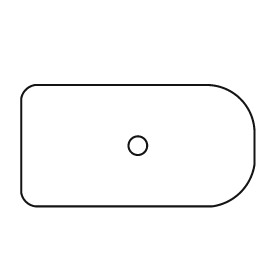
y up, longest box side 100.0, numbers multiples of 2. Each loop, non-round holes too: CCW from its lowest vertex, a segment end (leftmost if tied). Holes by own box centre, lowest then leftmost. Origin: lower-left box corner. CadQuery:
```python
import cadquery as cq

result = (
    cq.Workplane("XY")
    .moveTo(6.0, 0.0)
    .lineTo(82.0, 0.0)
    .threePointArc((94.0, 6.0), (100.0, 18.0))
    .lineTo(100.0, 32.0)
    .threePointArc((94.0, 46.0), (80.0, 52.0))
    .lineTo(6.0, 52.0)
    .threePointArc((2.0, 50.0), (0.0, 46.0))
    .lineTo(0.0, 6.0)
    .threePointArc((2.0, 2.0), (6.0, 0.0))
    .close()
    .moveTo(50.0, 26.0)
    .circle(4.0)
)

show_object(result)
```